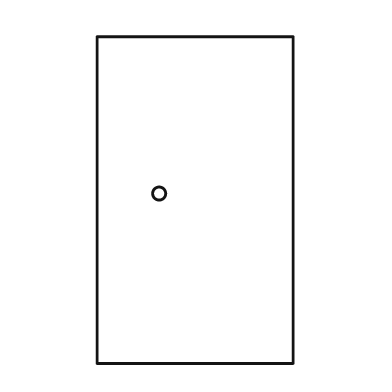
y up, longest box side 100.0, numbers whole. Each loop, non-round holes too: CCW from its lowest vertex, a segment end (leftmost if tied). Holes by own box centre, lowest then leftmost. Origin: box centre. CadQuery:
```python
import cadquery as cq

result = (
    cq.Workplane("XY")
    .moveTo(-30.0, -50.0)
    .lineTo(30.0, -50.0)
    .lineTo(30.0, 50.0)
    .lineTo(-30.0, 50.0)
    .close()
    .moveTo(-11.0, 2.0)
    .circle(2.0)
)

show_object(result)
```